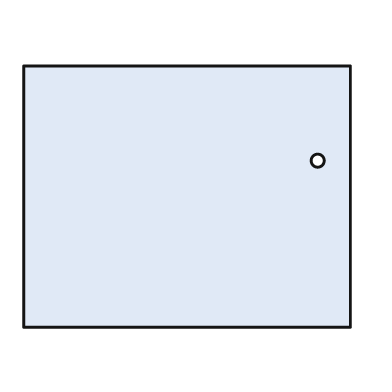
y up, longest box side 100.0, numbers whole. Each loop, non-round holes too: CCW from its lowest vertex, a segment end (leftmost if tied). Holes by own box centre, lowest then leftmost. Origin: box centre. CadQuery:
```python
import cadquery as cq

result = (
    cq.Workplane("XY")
    .moveTo(-50.0, -40.0)
    .lineTo(50.0, -40.0)
    .lineTo(50.0, 40.0)
    .lineTo(-50.0, 40.0)
    .close()
    .moveTo(40.0, 11.0)
    .circle(2.0)
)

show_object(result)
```